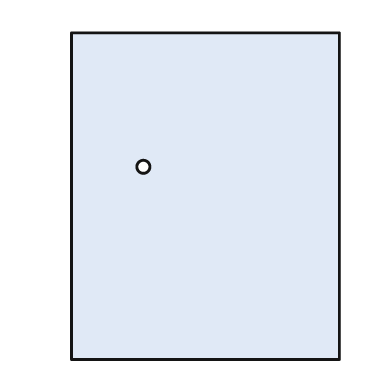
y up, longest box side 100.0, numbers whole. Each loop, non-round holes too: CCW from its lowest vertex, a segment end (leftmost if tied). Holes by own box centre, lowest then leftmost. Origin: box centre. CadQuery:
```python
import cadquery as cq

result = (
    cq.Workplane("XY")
    .moveTo(-41.0, -50.0)
    .lineTo(41.0, -50.0)
    .lineTo(41.0, 50.0)
    .lineTo(-41.0, 50.0)
    .close()
    .moveTo(-19.0, 9.0)
    .circle(2.0)
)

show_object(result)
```